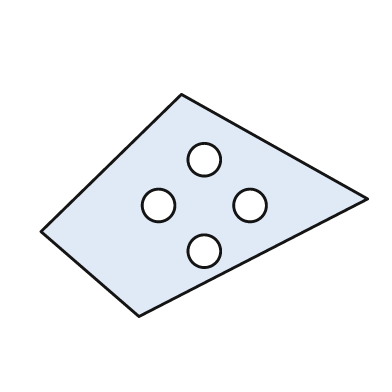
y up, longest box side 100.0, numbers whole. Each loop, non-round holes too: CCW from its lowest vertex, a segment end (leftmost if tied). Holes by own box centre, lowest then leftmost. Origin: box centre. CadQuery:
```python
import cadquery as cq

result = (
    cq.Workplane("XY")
    .moveTo(-20.0, -34.0)
    .lineTo(50.0, 2.0)
    .lineTo(-7.0, 34.0)
    .lineTo(-50.0, -8.0)
    .close()
    .moveTo(0.0, -14.0)
    .circle(5.0)
    .moveTo(-14.0, 0.0)
    .circle(5.0)
    .moveTo(14.0, 0.0)
    .circle(5.0)
    .moveTo(0.0, 14.0)
    .circle(5.0)
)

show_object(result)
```